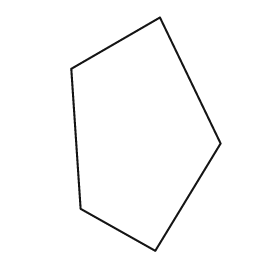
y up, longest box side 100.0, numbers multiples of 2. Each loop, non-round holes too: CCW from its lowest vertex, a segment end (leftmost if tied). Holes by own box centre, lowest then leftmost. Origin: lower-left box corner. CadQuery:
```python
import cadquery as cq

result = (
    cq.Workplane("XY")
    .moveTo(36.0, 0.0)
    .lineTo(64.0, 46.0)
    .lineTo(38.0, 100.0)
    .lineTo(0.0, 78.0)
    .lineTo(4.0, 18.0)
    .close()
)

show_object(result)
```